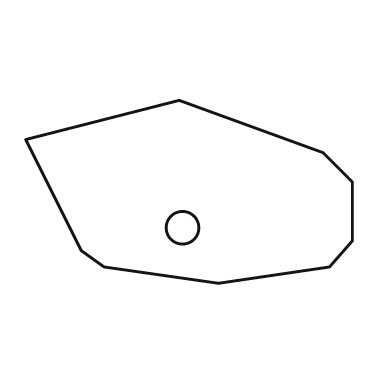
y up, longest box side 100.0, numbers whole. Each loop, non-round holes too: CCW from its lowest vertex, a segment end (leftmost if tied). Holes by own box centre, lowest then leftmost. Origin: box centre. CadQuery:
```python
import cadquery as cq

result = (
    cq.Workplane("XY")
    .moveTo(9.0, -28.0)
    .lineTo(43.0, -23.0)
    .lineTo(50.0, -15.0)
    .lineTo(50.0, 3.0)
    .lineTo(41.0, 12.0)
    .lineTo(-3.0, 28.0)
    .lineTo(-50.0, 16.0)
    .lineTo(-33.0, -18.0)
    .lineTo(-26.0, -23.0)
    .close()
    .moveTo(-2.0, -11.0)
    .circle(5.0)
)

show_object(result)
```